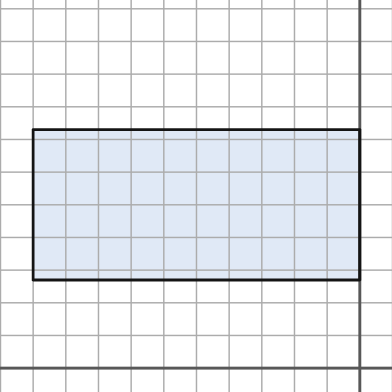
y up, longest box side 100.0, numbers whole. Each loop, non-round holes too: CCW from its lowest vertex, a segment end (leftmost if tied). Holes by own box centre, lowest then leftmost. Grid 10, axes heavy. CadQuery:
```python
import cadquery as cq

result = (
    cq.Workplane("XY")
    .moveTo(-100.0, 27.0)
    .lineTo(0.0, 27.0)
    .lineTo(0.0, 73.0)
    .lineTo(-100.0, 73.0)
    .close()
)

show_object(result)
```